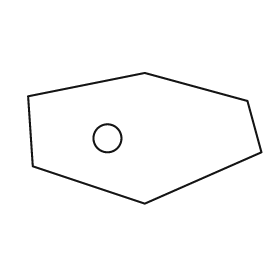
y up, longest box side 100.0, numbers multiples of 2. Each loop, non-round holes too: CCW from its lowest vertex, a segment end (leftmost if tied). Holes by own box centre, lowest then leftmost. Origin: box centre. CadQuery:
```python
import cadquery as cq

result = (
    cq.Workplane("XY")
    .moveTo(0.0, -28.0)
    .lineTo(50.0, -6.0)
    .lineTo(44.0, 16.0)
    .lineTo(0.0, 28.0)
    .lineTo(-50.0, 18.0)
    .lineTo(-48.0, -12.0)
    .close()
    .moveTo(-16.0, 0.0)
    .circle(6.0)
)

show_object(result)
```